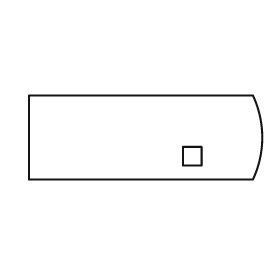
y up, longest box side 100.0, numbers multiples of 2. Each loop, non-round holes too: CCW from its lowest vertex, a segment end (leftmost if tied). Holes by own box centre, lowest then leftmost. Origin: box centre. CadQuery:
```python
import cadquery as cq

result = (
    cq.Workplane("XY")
    .moveTo(-50.0, -18.0)
    .lineTo(46.0, -18.0)
    .threePointArc((50.0, 0.0), (46.0, 18.0))
    .lineTo(-50.0, 18.0)
    .close()
    .moveTo(16.0, -12.0)
    .lineTo(24.0, -12.0)
    .lineTo(24.0, -4.0)
    .lineTo(16.0, -4.0)
    .close()
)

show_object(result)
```